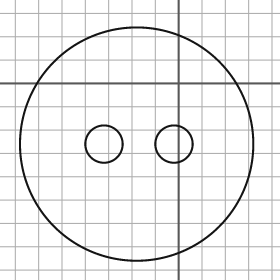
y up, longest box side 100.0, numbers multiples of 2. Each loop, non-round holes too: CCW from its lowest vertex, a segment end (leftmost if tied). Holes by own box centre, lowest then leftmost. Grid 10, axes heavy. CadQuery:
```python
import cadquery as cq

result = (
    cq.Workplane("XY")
    .moveTo(-18.0, -26.0)
    .circle(50.0)
    .moveTo(-32.0, -26.0)
    .circle(8.0)
    .moveTo(-2.0, -26.0)
    .circle(8.0)
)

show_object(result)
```